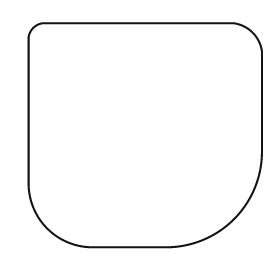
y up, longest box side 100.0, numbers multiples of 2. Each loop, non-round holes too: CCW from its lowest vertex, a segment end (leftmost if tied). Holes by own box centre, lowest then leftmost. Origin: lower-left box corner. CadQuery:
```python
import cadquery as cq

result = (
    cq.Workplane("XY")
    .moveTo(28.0, 0.0)
    .lineTo(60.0, 0.0)
    .threePointArc((88.0, 12.0), (100.0, 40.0))
    .lineTo(100.0, 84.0)
    .threePointArc((96.0, 92.0), (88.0, 96.0))
    .lineTo(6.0, 96.0)
    .threePointArc((2.0, 94.0), (0.0, 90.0))
    .lineTo(0.0, 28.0)
    .threePointArc((8.0, 8.0), (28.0, 0.0))
    .close()
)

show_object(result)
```